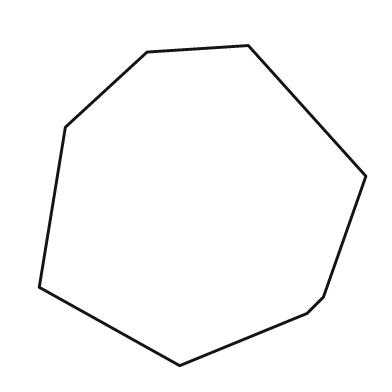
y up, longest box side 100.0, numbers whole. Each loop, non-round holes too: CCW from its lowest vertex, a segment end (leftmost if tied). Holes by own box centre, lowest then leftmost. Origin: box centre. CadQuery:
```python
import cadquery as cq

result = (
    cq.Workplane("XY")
    .moveTo(-7.0, -49.0)
    .lineTo(32.0, -33.0)
    .lineTo(37.0, -28.0)
    .lineTo(50.0, 9.0)
    .lineTo(14.0, 49.0)
    .lineTo(-17.0, 47.0)
    .lineTo(-42.0, 24.0)
    .lineTo(-50.0, -25.0)
    .close()
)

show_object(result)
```